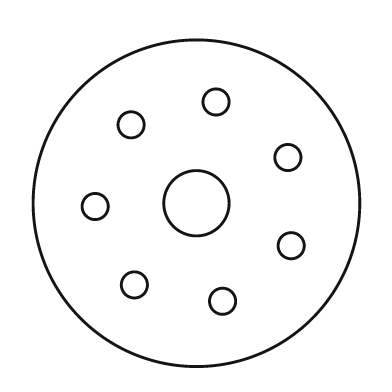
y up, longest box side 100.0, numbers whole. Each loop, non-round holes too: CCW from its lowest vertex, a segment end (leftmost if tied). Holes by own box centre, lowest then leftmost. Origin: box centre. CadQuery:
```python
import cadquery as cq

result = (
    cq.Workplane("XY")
    .moveTo(0.0, 0.0)
    .circle(50.0)
    .moveTo(8.0, -30.0)
    .circle(4.0)
    .moveTo(-19.0, -25.0)
    .circle(4.0)
    .moveTo(29.0, -13.0)
    .circle(4.0)
    .moveTo(-31.0, -1.0)
    .circle(4.0)
    .moveTo(0.0, 0.0)
    .circle(10.0)
    .moveTo(28.0, 14.0)
    .circle(4.0)
    .moveTo(-20.0, 24.0)
    .circle(4.0)
    .moveTo(6.0, 31.0)
    .circle(4.0)
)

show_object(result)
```